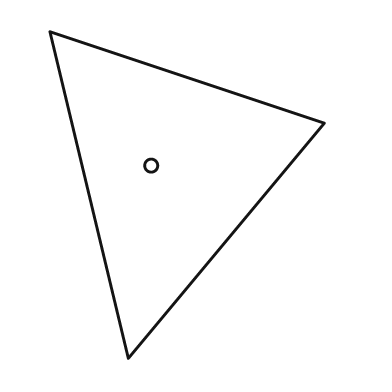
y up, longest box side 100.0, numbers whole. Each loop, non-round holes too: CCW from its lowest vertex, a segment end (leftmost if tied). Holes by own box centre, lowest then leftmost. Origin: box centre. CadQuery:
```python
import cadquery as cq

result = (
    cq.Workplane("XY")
    .moveTo(-18.0, -50.0)
    .lineTo(42.0, 22.0)
    .lineTo(-42.0, 50.0)
    .close()
    .moveTo(-11.0, 9.0)
    .circle(2.0)
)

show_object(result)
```